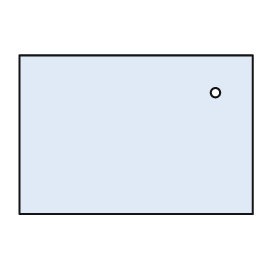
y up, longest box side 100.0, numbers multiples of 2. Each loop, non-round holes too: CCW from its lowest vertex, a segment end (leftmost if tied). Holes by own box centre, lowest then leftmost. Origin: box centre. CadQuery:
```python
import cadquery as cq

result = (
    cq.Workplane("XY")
    .moveTo(-50.0, -34.0)
    .lineTo(50.0, -34.0)
    .lineTo(50.0, 34.0)
    .lineTo(-50.0, 34.0)
    .close()
    .moveTo(34.0, 18.0)
    .circle(2.0)
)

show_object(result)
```